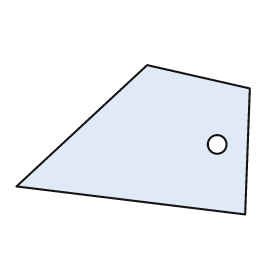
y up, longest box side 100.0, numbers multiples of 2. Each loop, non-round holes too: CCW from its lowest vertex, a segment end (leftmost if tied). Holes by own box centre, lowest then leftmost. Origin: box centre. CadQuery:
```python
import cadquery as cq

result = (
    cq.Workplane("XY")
    .moveTo(48.0, -32.0)
    .lineTo(50.0, 22.0)
    .lineTo(6.0, 32.0)
    .lineTo(-50.0, -20.0)
    .close()
    .moveTo(36.0, -2.0)
    .circle(4.0)
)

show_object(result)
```